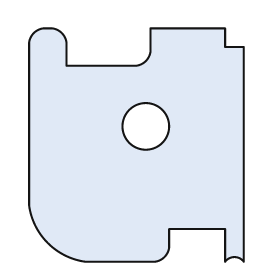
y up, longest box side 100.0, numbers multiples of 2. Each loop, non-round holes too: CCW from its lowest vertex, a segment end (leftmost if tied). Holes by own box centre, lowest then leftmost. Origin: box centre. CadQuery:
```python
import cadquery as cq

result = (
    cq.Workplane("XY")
    .moveTo(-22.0, -50.0)
    .lineTo(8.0, -50.0)
    .threePointArc((12.0, -48.0), (14.0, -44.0))
    .lineTo(14.0, -36.0)
    .lineTo(38.0, -36.0)
    .lineTo(38.0, -50.0)
    .threePointArc((42.0, -48.0), (46.0, -50.0))
    .lineTo(46.0, 42.0)
    .lineTo(38.0, 42.0)
    .lineTo(38.0, 50.0)
    .lineTo(6.0, 50.0)
    .lineTo(6.0, 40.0)
    .threePointArc((4.0, 36.0), (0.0, 34.0))
    .lineTo(-30.0, 34.0)
    .lineTo(-30.0, 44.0)
    .threePointArc((-32.0, 48.0), (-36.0, 50.0))
    .lineTo(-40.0, 50.0)
    .threePointArc((-44.0, 48.0), (-46.0, 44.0))
    .lineTo(-46.0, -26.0)
    .threePointArc((-38.0, -42.0), (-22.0, -50.0))
    .close()
    .moveTo(4.0, 8.0)
    .circle(10.0)
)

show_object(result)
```